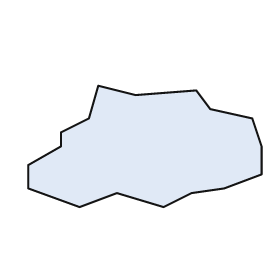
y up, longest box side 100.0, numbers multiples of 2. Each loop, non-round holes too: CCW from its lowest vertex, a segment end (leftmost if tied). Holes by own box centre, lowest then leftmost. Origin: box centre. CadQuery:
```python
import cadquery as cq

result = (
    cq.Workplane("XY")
    .moveTo(-28.0, -26.0)
    .lineTo(-12.0, -20.0)
    .lineTo(8.0, -26.0)
    .lineTo(20.0, -20.0)
    .lineTo(34.0, -18.0)
    .lineTo(50.0, -12.0)
    .lineTo(50.0, 0.0)
    .lineTo(46.0, 12.0)
    .lineTo(28.0, 16.0)
    .lineTo(22.0, 24.0)
    .lineTo(-4.0, 22.0)
    .lineTo(-20.0, 26.0)
    .lineTo(-24.0, 12.0)
    .lineTo(-36.0, 6.0)
    .lineTo(-36.0, 0.0)
    .lineTo(-50.0, -8.0)
    .lineTo(-50.0, -18.0)
    .close()
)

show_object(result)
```